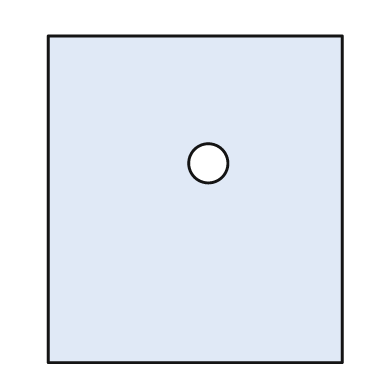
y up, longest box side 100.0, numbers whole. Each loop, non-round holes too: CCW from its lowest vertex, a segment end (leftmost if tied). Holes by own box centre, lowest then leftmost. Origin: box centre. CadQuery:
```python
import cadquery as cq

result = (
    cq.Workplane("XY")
    .moveTo(-45.0, -50.0)
    .lineTo(45.0, -50.0)
    .lineTo(45.0, 50.0)
    .lineTo(-45.0, 50.0)
    .close()
    .moveTo(4.0, 11.0)
    .circle(6.0)
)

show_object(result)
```